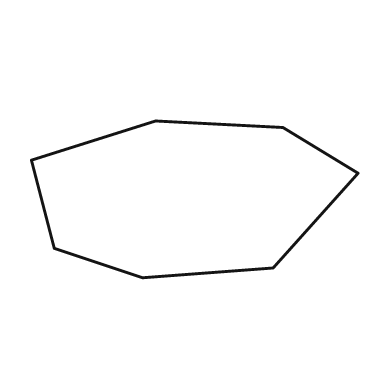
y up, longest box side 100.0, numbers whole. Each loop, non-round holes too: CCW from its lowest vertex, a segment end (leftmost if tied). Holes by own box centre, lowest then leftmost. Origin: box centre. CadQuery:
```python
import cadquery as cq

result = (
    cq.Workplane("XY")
    .moveTo(-16.0, -24.0)
    .lineTo(24.0, -21.0)
    .lineTo(50.0, 8.0)
    .lineTo(27.0, 22.0)
    .lineTo(-12.0, 24.0)
    .lineTo(-50.0, 12.0)
    .lineTo(-43.0, -15.0)
    .close()
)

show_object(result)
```